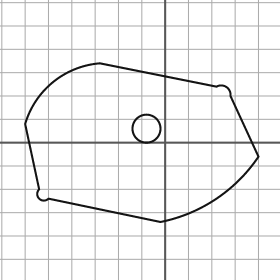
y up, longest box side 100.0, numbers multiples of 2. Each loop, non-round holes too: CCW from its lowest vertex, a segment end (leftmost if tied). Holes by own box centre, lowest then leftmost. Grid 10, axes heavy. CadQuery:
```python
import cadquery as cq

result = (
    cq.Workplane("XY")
    .moveTo(-2.0, -34.0)
    .threePointArc((22.0, -24.0), (40.0, -6.0))
    .lineTo(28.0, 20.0)
    .threePointArc((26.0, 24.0), (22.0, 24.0))
    .lineTo(-28.0, 34.0)
    .threePointArc((-48.0, 26.0), (-60.0, 8.0))
    .lineTo(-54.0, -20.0)
    .threePointArc((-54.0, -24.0), (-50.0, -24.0))
    .close()
    .moveTo(-8.0, 6.0)
    .circle(6.0)
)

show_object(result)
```